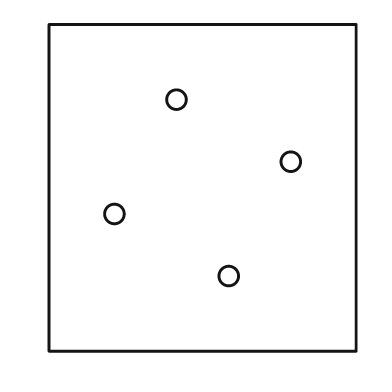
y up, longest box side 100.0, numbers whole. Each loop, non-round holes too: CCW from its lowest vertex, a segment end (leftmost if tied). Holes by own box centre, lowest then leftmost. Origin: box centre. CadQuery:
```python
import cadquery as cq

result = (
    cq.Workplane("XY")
    .moveTo(-47.0, -50.0)
    .lineTo(47.0, -50.0)
    .lineTo(47.0, 50.0)
    .lineTo(-47.0, 50.0)
    .close()
    .moveTo(8.0, -27.0)
    .circle(3.0)
    .moveTo(-27.0, -8.0)
    .circle(3.0)
    .moveTo(27.0, 8.0)
    .circle(3.0)
    .moveTo(-8.0, 27.0)
    .circle(3.0)
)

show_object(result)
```